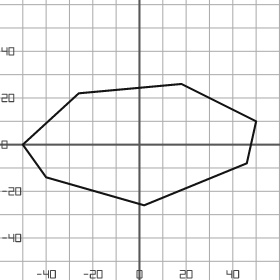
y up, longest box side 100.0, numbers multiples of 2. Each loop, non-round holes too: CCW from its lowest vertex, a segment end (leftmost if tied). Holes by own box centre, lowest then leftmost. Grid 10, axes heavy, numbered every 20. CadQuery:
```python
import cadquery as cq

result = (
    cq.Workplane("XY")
    .moveTo(2.0, -26.0)
    .lineTo(46.0, -8.0)
    .lineTo(50.0, 10.0)
    .lineTo(18.0, 26.0)
    .lineTo(-26.0, 22.0)
    .lineTo(-50.0, 0.0)
    .lineTo(-40.0, -14.0)
    .close()
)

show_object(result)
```